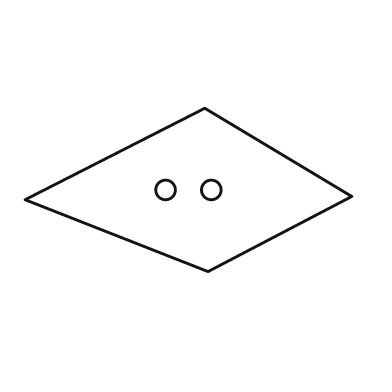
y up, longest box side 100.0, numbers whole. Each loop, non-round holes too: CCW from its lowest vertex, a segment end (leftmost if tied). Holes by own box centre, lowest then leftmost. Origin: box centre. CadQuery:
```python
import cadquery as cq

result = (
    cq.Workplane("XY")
    .moveTo(6.0, -25.0)
    .lineTo(50.0, -2.0)
    .lineTo(5.0, 25.0)
    .lineTo(-50.0, -3.0)
    .close()
    .moveTo(-7.0, 0.0)
    .circle(3.0)
    .moveTo(7.0, 0.0)
    .circle(3.0)
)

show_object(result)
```